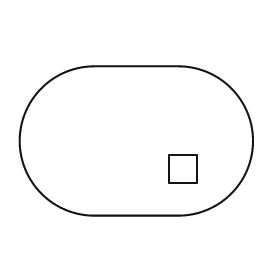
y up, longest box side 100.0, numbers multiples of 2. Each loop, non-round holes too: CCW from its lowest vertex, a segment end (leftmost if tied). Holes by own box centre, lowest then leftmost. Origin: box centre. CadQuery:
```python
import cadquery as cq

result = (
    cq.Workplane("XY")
    .moveTo(-18.0, -32.0)
    .lineTo(18.0, -32.0)
    .threePointArc((50.0, 0.0), (18.0, 32.0))
    .lineTo(-18.0, 32.0)
    .threePointArc((-50.0, 0.0), (-18.0, -32.0))
    .close()
    .moveTo(14.0, -18.0)
    .lineTo(26.0, -18.0)
    .lineTo(26.0, -6.0)
    .lineTo(14.0, -6.0)
    .close()
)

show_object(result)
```